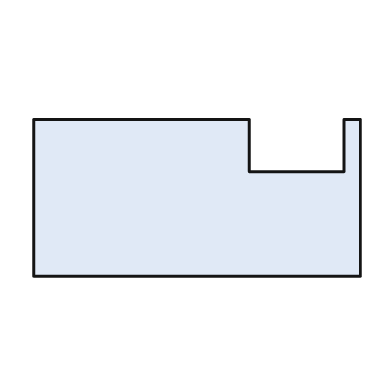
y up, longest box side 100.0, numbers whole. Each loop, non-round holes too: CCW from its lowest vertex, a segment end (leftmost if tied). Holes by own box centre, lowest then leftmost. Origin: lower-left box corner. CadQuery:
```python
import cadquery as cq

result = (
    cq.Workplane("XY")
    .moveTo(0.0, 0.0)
    .lineTo(100.0, 0.0)
    .lineTo(100.0, 48.0)
    .lineTo(95.0, 48.0)
    .lineTo(95.0, 32.0)
    .lineTo(66.0, 32.0)
    .lineTo(66.0, 48.0)
    .lineTo(0.0, 48.0)
    .close()
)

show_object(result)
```